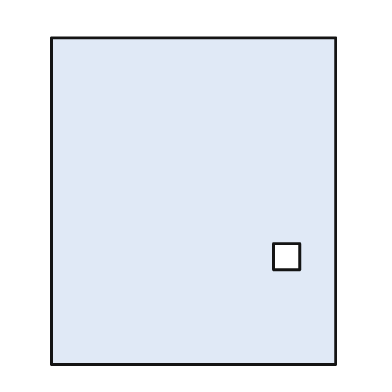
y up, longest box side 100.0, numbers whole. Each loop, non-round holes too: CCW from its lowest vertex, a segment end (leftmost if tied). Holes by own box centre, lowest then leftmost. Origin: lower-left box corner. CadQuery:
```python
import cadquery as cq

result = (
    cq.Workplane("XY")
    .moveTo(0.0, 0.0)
    .lineTo(87.0, 0.0)
    .lineTo(87.0, 100.0)
    .lineTo(0.0, 100.0)
    .close()
    .moveTo(68.0, 29.0)
    .lineTo(76.0, 29.0)
    .lineTo(76.0, 37.0)
    .lineTo(68.0, 37.0)
    .close()
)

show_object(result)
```